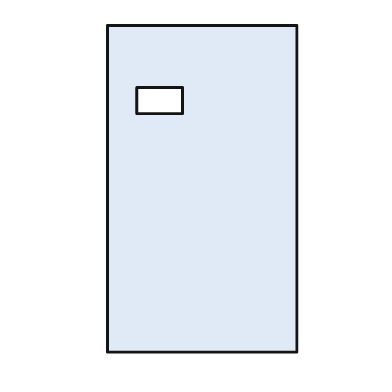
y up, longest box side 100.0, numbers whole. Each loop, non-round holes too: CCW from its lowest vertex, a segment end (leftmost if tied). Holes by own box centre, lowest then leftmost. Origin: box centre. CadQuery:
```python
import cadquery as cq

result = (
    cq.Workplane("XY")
    .moveTo(-29.0, -50.0)
    .lineTo(29.0, -50.0)
    .lineTo(29.0, 50.0)
    .lineTo(-29.0, 50.0)
    .close()
    .moveTo(-20.0, 23.0)
    .lineTo(-6.0, 23.0)
    .lineTo(-6.0, 31.0)
    .lineTo(-20.0, 31.0)
    .close()
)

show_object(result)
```